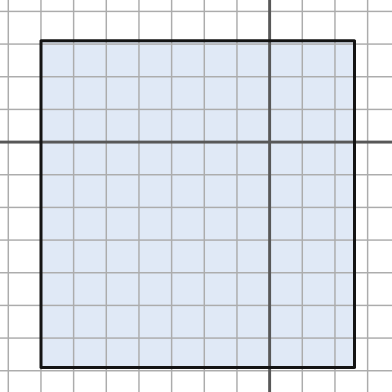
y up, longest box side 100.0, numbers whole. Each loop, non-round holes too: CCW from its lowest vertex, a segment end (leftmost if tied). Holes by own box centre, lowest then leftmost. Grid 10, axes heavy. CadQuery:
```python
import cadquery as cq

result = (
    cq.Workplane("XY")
    .moveTo(-70.0, -69.0)
    .lineTo(26.0, -69.0)
    .lineTo(26.0, 31.0)
    .lineTo(-70.0, 31.0)
    .close()
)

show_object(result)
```